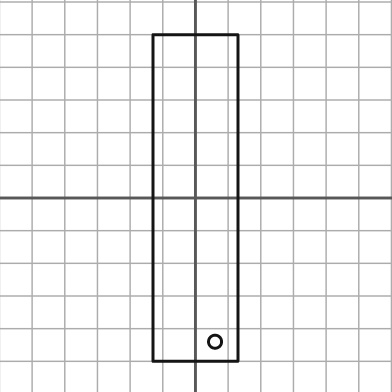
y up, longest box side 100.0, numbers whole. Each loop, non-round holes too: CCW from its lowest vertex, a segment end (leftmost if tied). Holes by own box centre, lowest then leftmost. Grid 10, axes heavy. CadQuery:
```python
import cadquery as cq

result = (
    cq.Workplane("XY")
    .moveTo(-13.0, -50.0)
    .lineTo(13.0, -50.0)
    .lineTo(13.0, 50.0)
    .lineTo(-13.0, 50.0)
    .close()
    .moveTo(6.0, -44.0)
    .circle(2.0)
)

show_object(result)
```